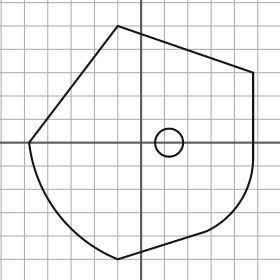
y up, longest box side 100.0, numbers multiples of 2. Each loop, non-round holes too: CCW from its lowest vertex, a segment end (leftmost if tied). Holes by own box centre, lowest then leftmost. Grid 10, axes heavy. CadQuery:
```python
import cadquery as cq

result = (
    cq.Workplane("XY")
    .moveTo(-10.0, -50.0)
    .lineTo(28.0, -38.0)
    .threePointArc((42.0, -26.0), (48.0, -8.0))
    .lineTo(48.0, 30.0)
    .lineTo(-10.0, 50.0)
    .lineTo(-48.0, 0.0)
    .threePointArc((-36.0, -30.0), (-10.0, -50.0))
    .close()
    .moveTo(12.0, 0.0)
    .circle(6.0)
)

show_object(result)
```